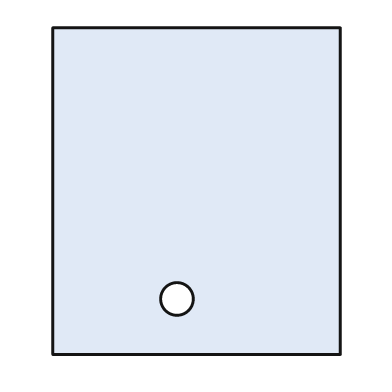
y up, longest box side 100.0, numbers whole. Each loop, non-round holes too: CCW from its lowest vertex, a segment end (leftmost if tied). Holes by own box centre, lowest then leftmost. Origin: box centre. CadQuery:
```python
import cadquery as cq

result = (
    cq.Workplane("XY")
    .moveTo(-44.0, -50.0)
    .lineTo(44.0, -50.0)
    .lineTo(44.0, 50.0)
    .lineTo(-44.0, 50.0)
    .close()
    .moveTo(-6.0, -33.0)
    .circle(5.0)
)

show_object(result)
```